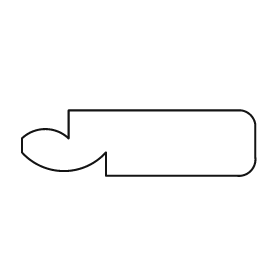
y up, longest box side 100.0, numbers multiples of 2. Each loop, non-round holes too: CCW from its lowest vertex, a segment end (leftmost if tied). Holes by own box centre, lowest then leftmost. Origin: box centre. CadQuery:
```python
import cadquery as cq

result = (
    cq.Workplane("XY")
    .moveTo(-14.0, -14.0)
    .lineTo(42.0, -14.0)
    .threePointArc((48.0, -12.0), (50.0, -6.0))
    .lineTo(50.0, 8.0)
    .threePointArc((48.0, 12.0), (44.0, 14.0))
    .lineTo(-30.0, 14.0)
    .lineTo(-30.0, 2.0)
    .threePointArc((-40.0, 6.0), (-50.0, 2.0))
    .lineTo(-50.0, -4.0)
    .threePointArc((-32.0, -12.0), (-14.0, -4.0))
    .close()
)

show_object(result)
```